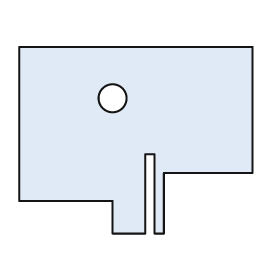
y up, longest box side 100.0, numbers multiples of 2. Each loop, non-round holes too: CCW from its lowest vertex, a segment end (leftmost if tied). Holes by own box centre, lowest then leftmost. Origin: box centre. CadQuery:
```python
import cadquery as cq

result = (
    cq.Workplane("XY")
    .moveTo(-10.0, -40.0)
    .lineTo(4.0, -40.0)
    .lineTo(4.0, -6.0)
    .lineTo(8.0, -6.0)
    .lineTo(8.0, -40.0)
    .lineTo(12.0, -40.0)
    .lineTo(12.0, -14.0)
    .lineTo(50.0, -14.0)
    .lineTo(50.0, 40.0)
    .lineTo(-50.0, 40.0)
    .lineTo(-50.0, -26.0)
    .lineTo(-10.0, -26.0)
    .close()
    .moveTo(-10.0, 18.0)
    .circle(6.0)
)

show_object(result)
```